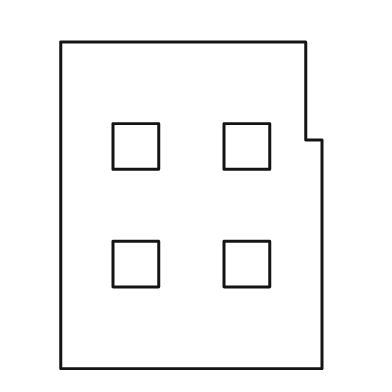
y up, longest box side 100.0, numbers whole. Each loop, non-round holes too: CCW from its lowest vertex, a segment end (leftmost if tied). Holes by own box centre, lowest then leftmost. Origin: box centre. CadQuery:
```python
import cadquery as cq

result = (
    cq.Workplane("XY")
    .moveTo(-40.0, -50.0)
    .lineTo(40.0, -50.0)
    .lineTo(40.0, 20.0)
    .lineTo(35.0, 20.0)
    .lineTo(35.0, 50.0)
    .lineTo(-40.0, 50.0)
    .close()
    .moveTo(-24.0, -25.0)
    .lineTo(-10.0, -25.0)
    .lineTo(-10.0, -11.0)
    .lineTo(-24.0, -11.0)
    .close()
    .moveTo(10.0, -25.0)
    .lineTo(24.0, -25.0)
    .lineTo(24.0, -11.0)
    .lineTo(10.0, -11.0)
    .close()
    .moveTo(-24.0, 11.0)
    .lineTo(-10.0, 11.0)
    .lineTo(-10.0, 25.0)
    .lineTo(-24.0, 25.0)
    .close()
    .moveTo(10.0, 11.0)
    .lineTo(24.0, 11.0)
    .lineTo(24.0, 25.0)
    .lineTo(10.0, 25.0)
    .close()
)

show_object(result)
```